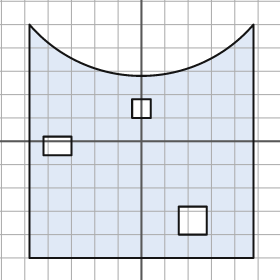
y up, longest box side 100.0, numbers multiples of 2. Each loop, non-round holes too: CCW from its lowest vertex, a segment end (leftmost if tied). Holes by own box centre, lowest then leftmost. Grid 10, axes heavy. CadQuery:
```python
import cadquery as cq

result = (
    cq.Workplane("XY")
    .moveTo(-48.0, -50.0)
    .lineTo(48.0, -50.0)
    .lineTo(48.0, 50.0)
    .threePointArc((0.0, 28.0), (-48.0, 50.0))
    .close()
    .moveTo(16.0, -40.0)
    .lineTo(28.0, -40.0)
    .lineTo(28.0, -28.0)
    .lineTo(16.0, -28.0)
    .close()
    .moveTo(-42.0, -6.0)
    .lineTo(-30.0, -6.0)
    .lineTo(-30.0, 2.0)
    .lineTo(-42.0, 2.0)
    .close()
    .moveTo(-4.0, 10.0)
    .lineTo(4.0, 10.0)
    .lineTo(4.0, 18.0)
    .lineTo(-4.0, 18.0)
    .close()
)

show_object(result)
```